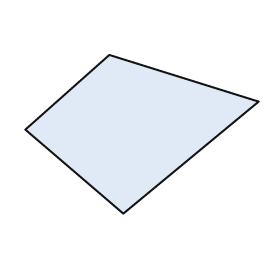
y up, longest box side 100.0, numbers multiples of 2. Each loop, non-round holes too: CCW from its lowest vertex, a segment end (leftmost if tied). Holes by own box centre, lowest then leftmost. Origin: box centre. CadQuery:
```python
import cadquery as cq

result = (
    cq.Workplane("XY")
    .moveTo(-8.0, -34.0)
    .lineTo(50.0, 14.0)
    .lineTo(-14.0, 34.0)
    .lineTo(-50.0, 2.0)
    .close()
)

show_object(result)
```